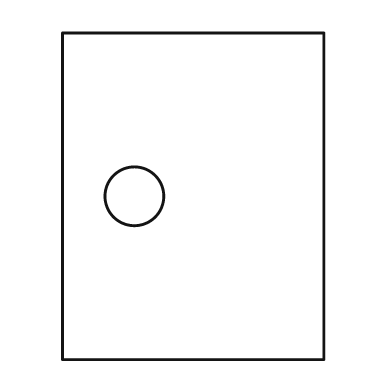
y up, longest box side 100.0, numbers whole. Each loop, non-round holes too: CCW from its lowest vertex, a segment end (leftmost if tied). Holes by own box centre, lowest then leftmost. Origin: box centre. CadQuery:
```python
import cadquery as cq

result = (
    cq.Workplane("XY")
    .moveTo(-40.0, -50.0)
    .lineTo(40.0, -50.0)
    .lineTo(40.0, 50.0)
    .lineTo(-40.0, 50.0)
    .close()
    .moveTo(-18.0, 0.0)
    .circle(9.0)
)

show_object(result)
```